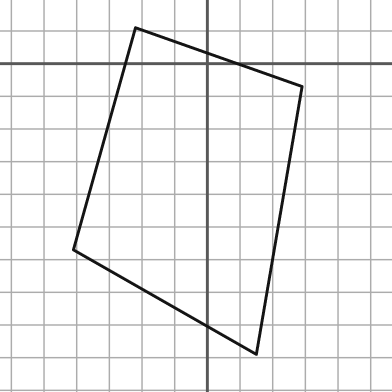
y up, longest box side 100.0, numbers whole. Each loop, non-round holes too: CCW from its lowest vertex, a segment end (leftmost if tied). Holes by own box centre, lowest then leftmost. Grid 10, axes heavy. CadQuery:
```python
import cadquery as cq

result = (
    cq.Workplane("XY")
    .moveTo(15.0, -89.0)
    .lineTo(29.0, -7.0)
    .lineTo(-22.0, 11.0)
    .lineTo(-41.0, -57.0)
    .close()
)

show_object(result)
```